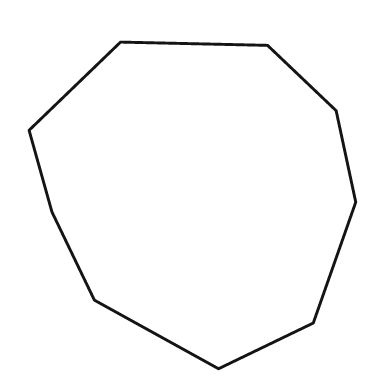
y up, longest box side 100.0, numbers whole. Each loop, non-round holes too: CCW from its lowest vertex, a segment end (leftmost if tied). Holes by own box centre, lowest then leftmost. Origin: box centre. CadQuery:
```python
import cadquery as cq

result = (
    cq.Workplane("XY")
    .moveTo(8.0, -50.0)
    .lineTo(37.0, -36.0)
    .lineTo(50.0, 1.0)
    .lineTo(44.0, 29.0)
    .lineTo(23.0, 49.0)
    .lineTo(-22.0, 50.0)
    .lineTo(-50.0, 23.0)
    .lineTo(-43.0, -2.0)
    .lineTo(-30.0, -29.0)
    .close()
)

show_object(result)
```